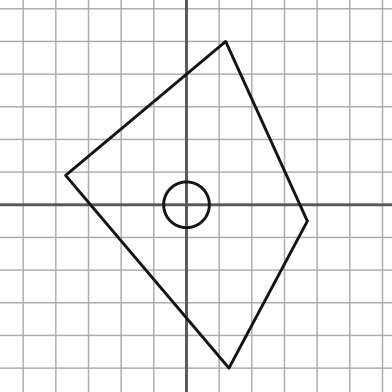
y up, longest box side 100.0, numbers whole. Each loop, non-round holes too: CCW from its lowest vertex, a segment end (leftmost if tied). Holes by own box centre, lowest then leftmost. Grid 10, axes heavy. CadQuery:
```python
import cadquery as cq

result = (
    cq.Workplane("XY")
    .moveTo(13.0, -50.0)
    .lineTo(37.0, -5.0)
    .lineTo(12.0, 50.0)
    .lineTo(-37.0, 9.0)
    .close()
    .moveTo(0.0, 0.0)
    .circle(7.0)
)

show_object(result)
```